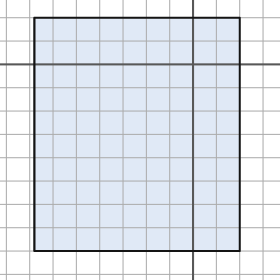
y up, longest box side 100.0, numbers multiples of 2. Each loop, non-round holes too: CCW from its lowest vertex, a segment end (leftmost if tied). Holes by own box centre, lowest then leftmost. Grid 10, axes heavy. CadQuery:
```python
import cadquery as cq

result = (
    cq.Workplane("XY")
    .moveTo(-68.0, -80.0)
    .lineTo(20.0, -80.0)
    .lineTo(20.0, 20.0)
    .lineTo(-68.0, 20.0)
    .close()
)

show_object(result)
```